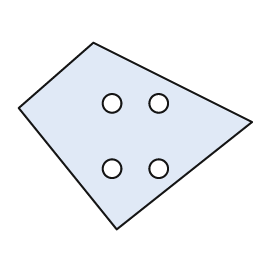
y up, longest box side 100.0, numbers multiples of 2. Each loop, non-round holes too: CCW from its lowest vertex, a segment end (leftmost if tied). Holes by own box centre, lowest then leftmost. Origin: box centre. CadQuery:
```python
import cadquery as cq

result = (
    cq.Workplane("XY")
    .moveTo(-8.0, -40.0)
    .lineTo(50.0, 6.0)
    .lineTo(-18.0, 40.0)
    .lineTo(-50.0, 12.0)
    .close()
    .moveTo(-10.0, -14.0)
    .circle(4.0)
    .moveTo(10.0, -14.0)
    .circle(4.0)
    .moveTo(-10.0, 14.0)
    .circle(4.0)
    .moveTo(10.0, 14.0)
    .circle(4.0)
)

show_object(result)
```